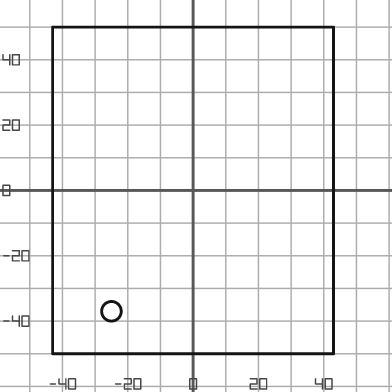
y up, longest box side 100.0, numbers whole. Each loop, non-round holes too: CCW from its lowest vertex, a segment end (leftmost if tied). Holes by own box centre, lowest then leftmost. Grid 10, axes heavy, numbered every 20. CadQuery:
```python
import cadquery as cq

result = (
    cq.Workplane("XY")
    .moveTo(-43.0, -50.0)
    .lineTo(43.0, -50.0)
    .lineTo(43.0, 50.0)
    .lineTo(-43.0, 50.0)
    .close()
    .moveTo(-25.0, -37.0)
    .circle(3.0)
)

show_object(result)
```